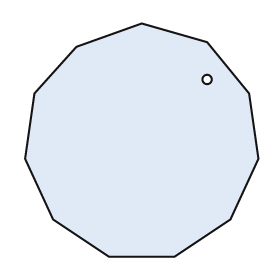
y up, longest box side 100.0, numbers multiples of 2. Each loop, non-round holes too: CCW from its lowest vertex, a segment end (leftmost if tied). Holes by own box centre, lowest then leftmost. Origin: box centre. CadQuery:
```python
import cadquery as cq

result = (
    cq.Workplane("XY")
    .moveTo(-14.0, -50.0)
    .lineTo(14.0, -50.0)
    .lineTo(38.0, -34.0)
    .lineTo(50.0, -8.0)
    .lineTo(46.0, 20.0)
    .lineTo(28.0, 42.0)
    .lineTo(0.0, 50.0)
    .lineTo(-28.0, 40.0)
    .lineTo(-46.0, 20.0)
    .lineTo(-50.0, -8.0)
    .lineTo(-38.0, -34.0)
    .close()
    .moveTo(28.0, 26.0)
    .circle(2.0)
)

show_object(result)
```